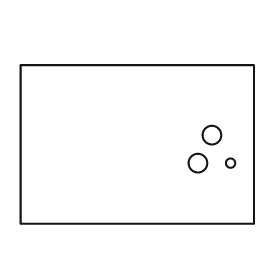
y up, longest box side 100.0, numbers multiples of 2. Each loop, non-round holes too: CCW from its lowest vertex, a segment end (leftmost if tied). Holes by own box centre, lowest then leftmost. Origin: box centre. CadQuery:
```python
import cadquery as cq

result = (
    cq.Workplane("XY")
    .moveTo(-50.0, -34.0)
    .lineTo(50.0, -34.0)
    .lineTo(50.0, 34.0)
    .lineTo(-50.0, 34.0)
    .close()
    .moveTo(26.0, -8.0)
    .circle(4.0)
    .moveTo(40.0, -8.0)
    .circle(2.0)
    .moveTo(32.0, 4.0)
    .circle(4.0)
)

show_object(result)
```